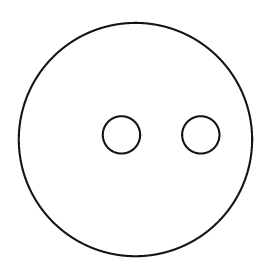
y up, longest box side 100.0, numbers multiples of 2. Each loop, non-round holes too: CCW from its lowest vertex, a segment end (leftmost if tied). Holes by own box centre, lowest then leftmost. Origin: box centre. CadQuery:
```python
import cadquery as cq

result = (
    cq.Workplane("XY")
    .moveTo(0.0, 0.0)
    .circle(50.0)
    .moveTo(-6.0, 2.0)
    .circle(8.0)
    .moveTo(28.0, 2.0)
    .circle(8.0)
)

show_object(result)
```